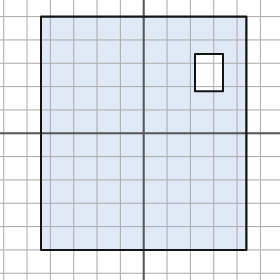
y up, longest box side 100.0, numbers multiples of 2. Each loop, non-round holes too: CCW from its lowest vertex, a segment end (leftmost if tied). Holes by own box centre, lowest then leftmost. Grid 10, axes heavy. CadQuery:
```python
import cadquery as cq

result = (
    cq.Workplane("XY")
    .moveTo(-44.0, -50.0)
    .lineTo(44.0, -50.0)
    .lineTo(44.0, 50.0)
    .lineTo(-44.0, 50.0)
    .close()
    .moveTo(22.0, 18.0)
    .lineTo(34.0, 18.0)
    .lineTo(34.0, 34.0)
    .lineTo(22.0, 34.0)
    .close()
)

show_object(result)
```